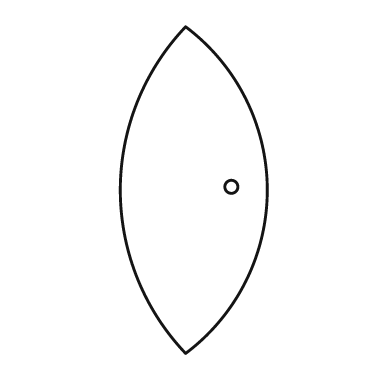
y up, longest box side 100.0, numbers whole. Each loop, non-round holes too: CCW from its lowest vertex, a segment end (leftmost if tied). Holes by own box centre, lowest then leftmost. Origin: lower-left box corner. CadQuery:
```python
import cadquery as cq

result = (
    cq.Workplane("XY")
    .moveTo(20.0, 0.0)
    .threePointArc((45.0, 50.0), (20.0, 100.0))
    .threePointArc((0.0, 50.0), (20.0, 0.0))
    .close()
    .moveTo(34.0, 51.0)
    .circle(2.0)
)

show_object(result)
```